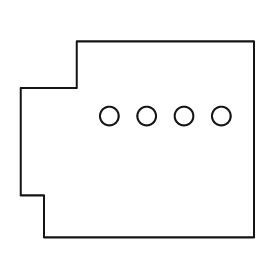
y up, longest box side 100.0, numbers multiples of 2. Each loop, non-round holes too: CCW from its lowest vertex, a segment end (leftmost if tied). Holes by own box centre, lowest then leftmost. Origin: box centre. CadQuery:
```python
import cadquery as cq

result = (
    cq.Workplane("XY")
    .moveTo(-40.0, -42.0)
    .lineTo(50.0, -42.0)
    .lineTo(50.0, 42.0)
    .lineTo(-26.0, 42.0)
    .lineTo(-26.0, 22.0)
    .lineTo(-50.0, 22.0)
    .lineTo(-50.0, -24.0)
    .lineTo(-40.0, -24.0)
    .close()
    .moveTo(-12.0, 10.0)
    .circle(4.0)
    .moveTo(4.0, 10.0)
    .circle(4.0)
    .moveTo(20.0, 10.0)
    .circle(4.0)
    .moveTo(36.0, 10.0)
    .circle(4.0)
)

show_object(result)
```